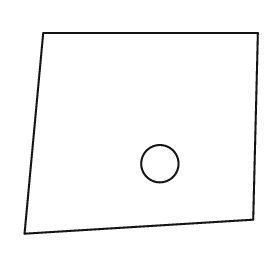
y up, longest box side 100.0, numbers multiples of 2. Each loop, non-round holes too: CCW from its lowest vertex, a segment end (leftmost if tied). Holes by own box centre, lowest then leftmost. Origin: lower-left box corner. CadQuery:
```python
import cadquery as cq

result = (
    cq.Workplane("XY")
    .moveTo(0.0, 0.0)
    .lineTo(98.0, 6.0)
    .lineTo(100.0, 86.0)
    .lineTo(8.0, 86.0)
    .close()
    .moveTo(58.0, 30.0)
    .circle(8.0)
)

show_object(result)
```